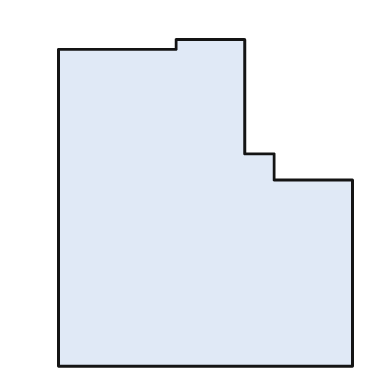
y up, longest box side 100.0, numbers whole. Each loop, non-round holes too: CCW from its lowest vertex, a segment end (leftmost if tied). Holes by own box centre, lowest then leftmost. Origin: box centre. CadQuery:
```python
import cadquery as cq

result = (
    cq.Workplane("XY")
    .moveTo(-45.0, -50.0)
    .lineTo(45.0, -50.0)
    .lineTo(45.0, 7.0)
    .lineTo(21.0, 7.0)
    .lineTo(21.0, 15.0)
    .lineTo(12.0, 15.0)
    .lineTo(12.0, 50.0)
    .lineTo(-9.0, 50.0)
    .lineTo(-9.0, 47.0)
    .lineTo(-45.0, 47.0)
    .close()
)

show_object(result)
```